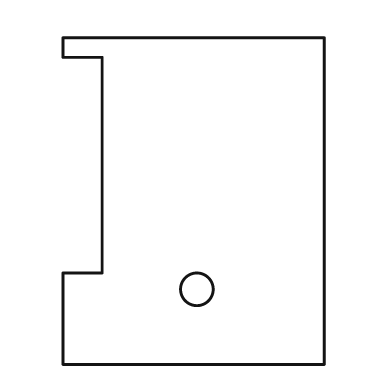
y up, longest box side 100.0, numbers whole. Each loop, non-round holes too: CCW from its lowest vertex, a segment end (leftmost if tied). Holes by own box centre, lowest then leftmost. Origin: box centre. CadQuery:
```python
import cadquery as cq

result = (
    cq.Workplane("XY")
    .moveTo(-40.0, -50.0)
    .lineTo(40.0, -50.0)
    .lineTo(40.0, 50.0)
    .lineTo(-40.0, 50.0)
    .lineTo(-40.0, 44.0)
    .lineTo(-28.0, 44.0)
    .lineTo(-28.0, -22.0)
    .lineTo(-40.0, -22.0)
    .close()
    .moveTo(1.0, -27.0)
    .circle(5.0)
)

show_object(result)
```